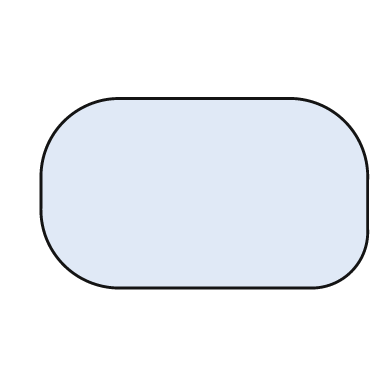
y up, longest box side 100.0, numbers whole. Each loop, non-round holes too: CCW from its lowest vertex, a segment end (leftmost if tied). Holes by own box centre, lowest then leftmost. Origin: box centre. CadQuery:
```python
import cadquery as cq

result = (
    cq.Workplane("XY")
    .moveTo(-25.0, -29.0)
    .lineTo(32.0, -29.0)
    .threePointArc((45.0, -24.0), (50.0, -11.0))
    .lineTo(50.0, 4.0)
    .threePointArc((43.0, 22.0), (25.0, 29.0))
    .lineTo(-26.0, 29.0)
    .threePointArc((-43.0, 22.0), (-50.0, 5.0))
    .lineTo(-50.0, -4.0)
    .threePointArc((-43.0, -22.0), (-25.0, -29.0))
    .close()
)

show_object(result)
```